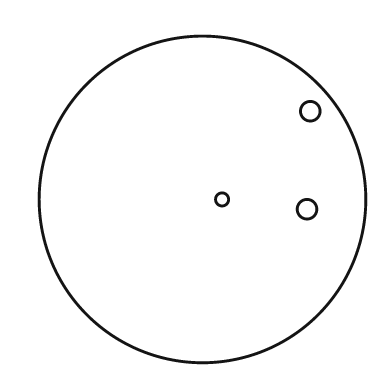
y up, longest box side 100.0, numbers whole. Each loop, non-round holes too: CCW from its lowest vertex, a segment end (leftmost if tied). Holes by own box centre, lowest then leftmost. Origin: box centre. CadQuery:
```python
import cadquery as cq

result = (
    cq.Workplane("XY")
    .moveTo(0.0, 0.0)
    .circle(50.0)
    .moveTo(32.0, -3.0)
    .circle(3.0)
    .moveTo(6.0, 0.0)
    .circle(2.0)
    .moveTo(33.0, 27.0)
    .circle(3.0)
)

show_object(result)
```